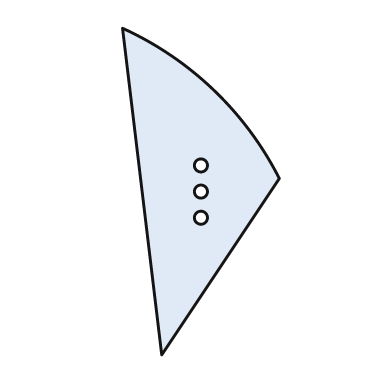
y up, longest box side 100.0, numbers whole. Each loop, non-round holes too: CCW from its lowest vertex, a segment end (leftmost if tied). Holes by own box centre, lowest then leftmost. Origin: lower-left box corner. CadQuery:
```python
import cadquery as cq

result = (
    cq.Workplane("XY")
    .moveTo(12.0, 0.0)
    .lineTo(48.0, 54.0)
    .threePointArc((28.0, 81.0), (0.0, 100.0))
    .close()
    .moveTo(24.0, 42.0)
    .circle(2.0)
    .moveTo(24.0, 50.0)
    .circle(2.0)
    .moveTo(24.0, 58.0)
    .circle(2.0)
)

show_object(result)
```